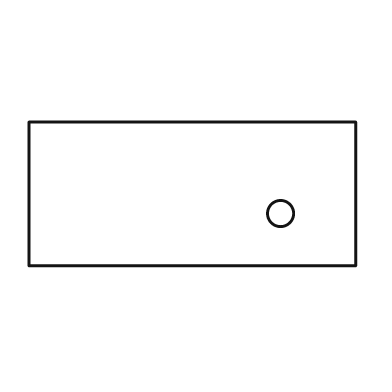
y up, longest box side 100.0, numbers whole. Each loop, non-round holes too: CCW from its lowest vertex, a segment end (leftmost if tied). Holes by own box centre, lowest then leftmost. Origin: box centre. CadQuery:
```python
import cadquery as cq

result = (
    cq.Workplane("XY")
    .moveTo(-50.0, -22.0)
    .lineTo(50.0, -22.0)
    .lineTo(50.0, 22.0)
    .lineTo(-50.0, 22.0)
    .close()
    .moveTo(27.0, -6.0)
    .circle(4.0)
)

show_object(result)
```